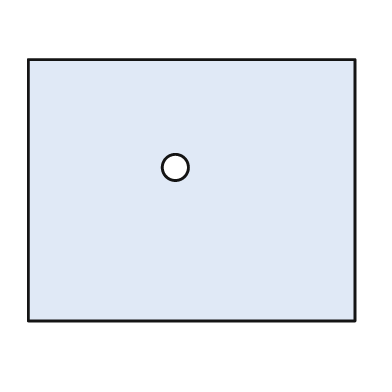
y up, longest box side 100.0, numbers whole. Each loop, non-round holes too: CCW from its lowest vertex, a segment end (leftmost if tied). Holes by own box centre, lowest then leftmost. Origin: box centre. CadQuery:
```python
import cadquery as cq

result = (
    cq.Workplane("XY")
    .moveTo(-50.0, -40.0)
    .lineTo(50.0, -40.0)
    .lineTo(50.0, 40.0)
    .lineTo(-50.0, 40.0)
    .close()
    .moveTo(-5.0, 7.0)
    .circle(4.0)
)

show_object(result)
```